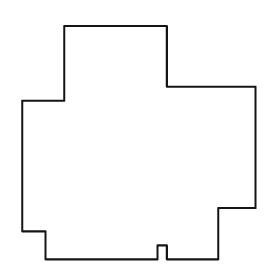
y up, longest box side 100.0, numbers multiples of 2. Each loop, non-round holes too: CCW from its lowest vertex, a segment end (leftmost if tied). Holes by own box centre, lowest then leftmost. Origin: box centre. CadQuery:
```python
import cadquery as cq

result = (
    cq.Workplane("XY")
    .moveTo(-40.0, -50.0)
    .lineTo(8.0, -50.0)
    .lineTo(8.0, -44.0)
    .lineTo(12.0, -44.0)
    .lineTo(12.0, -50.0)
    .lineTo(34.0, -50.0)
    .lineTo(34.0, -28.0)
    .lineTo(50.0, -28.0)
    .lineTo(50.0, 24.0)
    .lineTo(12.0, 24.0)
    .lineTo(12.0, 50.0)
    .lineTo(-32.0, 50.0)
    .lineTo(-32.0, 18.0)
    .lineTo(-50.0, 18.0)
    .lineTo(-50.0, -38.0)
    .lineTo(-40.0, -38.0)
    .close()
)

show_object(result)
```